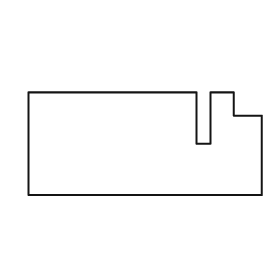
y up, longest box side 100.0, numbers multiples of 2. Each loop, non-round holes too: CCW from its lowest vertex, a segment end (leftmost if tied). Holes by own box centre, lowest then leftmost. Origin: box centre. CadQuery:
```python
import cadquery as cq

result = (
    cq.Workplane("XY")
    .moveTo(-50.0, -22.0)
    .lineTo(50.0, -22.0)
    .lineTo(50.0, 12.0)
    .lineTo(38.0, 12.0)
    .lineTo(38.0, 22.0)
    .lineTo(28.0, 22.0)
    .lineTo(28.0, 0.0)
    .lineTo(22.0, 0.0)
    .lineTo(22.0, 22.0)
    .lineTo(-50.0, 22.0)
    .close()
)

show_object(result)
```